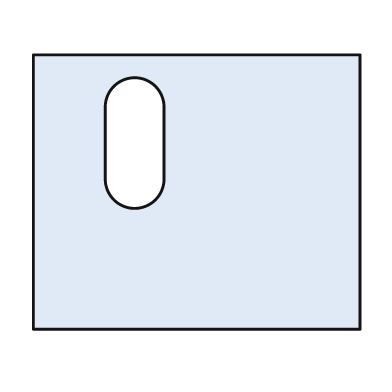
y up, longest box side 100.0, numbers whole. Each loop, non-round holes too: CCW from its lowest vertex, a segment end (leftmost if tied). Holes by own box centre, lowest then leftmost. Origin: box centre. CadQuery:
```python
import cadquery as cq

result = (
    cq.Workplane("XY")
    .moveTo(-50.0, -42.0)
    .lineTo(50.0, -42.0)
    .lineTo(50.0, 42.0)
    .lineTo(-50.0, 42.0)
    .close()
    .moveTo(-28.0, 4.0)
    .threePointArc((-19.0, -5.0), (-10.0, 4.0))
    .lineTo(-10.0, 26.0)
    .threePointArc((-19.0, 35.0), (-28.0, 26.0))
    .close()
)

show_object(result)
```